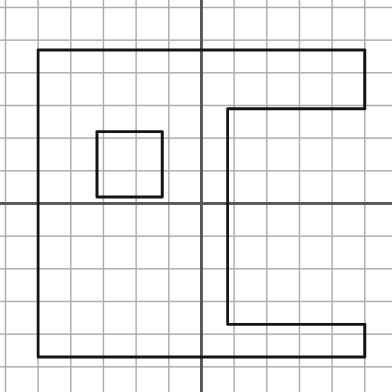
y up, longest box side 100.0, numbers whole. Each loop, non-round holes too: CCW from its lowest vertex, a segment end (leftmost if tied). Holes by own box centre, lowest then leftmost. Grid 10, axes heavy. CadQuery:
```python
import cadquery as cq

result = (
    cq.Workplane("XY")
    .moveTo(-50.0, -47.0)
    .lineTo(50.0, -47.0)
    .lineTo(50.0, -37.0)
    .lineTo(8.0, -37.0)
    .lineTo(8.0, 29.0)
    .lineTo(50.0, 29.0)
    .lineTo(50.0, 47.0)
    .lineTo(-50.0, 47.0)
    .close()
    .moveTo(-32.0, 2.0)
    .lineTo(-12.0, 2.0)
    .lineTo(-12.0, 22.0)
    .lineTo(-32.0, 22.0)
    .close()
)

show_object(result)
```